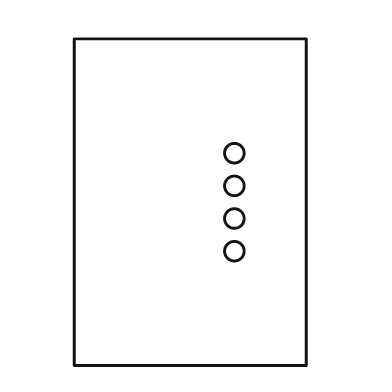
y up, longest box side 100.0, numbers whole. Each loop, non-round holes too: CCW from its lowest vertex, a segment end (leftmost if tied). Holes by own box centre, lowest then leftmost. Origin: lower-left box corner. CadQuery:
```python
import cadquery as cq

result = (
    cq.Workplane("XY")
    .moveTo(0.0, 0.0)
    .lineTo(71.0, 0.0)
    .lineTo(71.0, 100.0)
    .lineTo(0.0, 100.0)
    .close()
    .moveTo(49.0, 35.0)
    .circle(3.0)
    .moveTo(49.0, 45.0)
    .circle(3.0)
    .moveTo(49.0, 55.0)
    .circle(3.0)
    .moveTo(49.0, 65.0)
    .circle(3.0)
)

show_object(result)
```